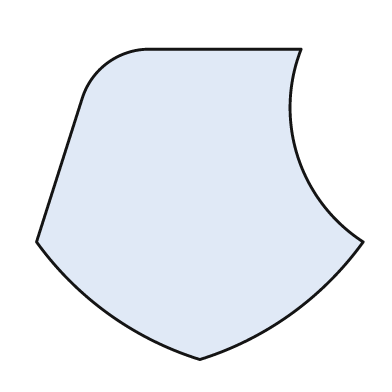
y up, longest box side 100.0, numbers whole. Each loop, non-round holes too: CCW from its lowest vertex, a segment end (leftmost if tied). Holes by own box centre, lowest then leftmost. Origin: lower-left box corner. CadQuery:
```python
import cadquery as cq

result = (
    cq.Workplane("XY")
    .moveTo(50.0, 0.0)
    .threePointArc((78.0, 14.0), (100.0, 36.0))
    .threePointArc((80.0, 62.0), (81.0, 95.0))
    .lineTo(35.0, 95.0)
    .threePointArc((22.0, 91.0), (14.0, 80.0))
    .lineTo(0.0, 36.0)
    .threePointArc((22.0, 14.0), (50.0, 0.0))
    .close()
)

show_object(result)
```